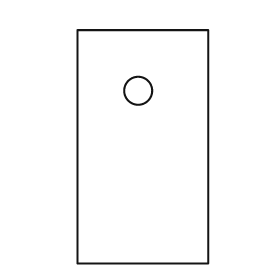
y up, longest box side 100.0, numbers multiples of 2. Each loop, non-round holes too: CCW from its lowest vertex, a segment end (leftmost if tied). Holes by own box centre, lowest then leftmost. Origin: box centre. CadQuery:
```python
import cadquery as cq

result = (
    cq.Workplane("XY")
    .moveTo(-28.0, -50.0)
    .lineTo(28.0, -50.0)
    .lineTo(28.0, 50.0)
    .lineTo(-28.0, 50.0)
    .close()
    .moveTo(-2.0, 24.0)
    .circle(6.0)
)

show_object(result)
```